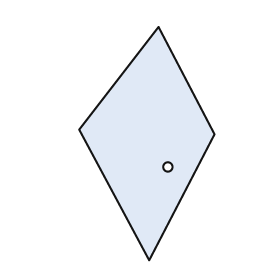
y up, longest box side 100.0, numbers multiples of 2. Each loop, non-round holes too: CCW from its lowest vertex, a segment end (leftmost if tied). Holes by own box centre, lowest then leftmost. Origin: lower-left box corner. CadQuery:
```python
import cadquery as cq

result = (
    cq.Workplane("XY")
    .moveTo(30.0, 0.0)
    .lineTo(58.0, 54.0)
    .lineTo(34.0, 100.0)
    .lineTo(0.0, 56.0)
    .close()
    .moveTo(38.0, 40.0)
    .circle(2.0)
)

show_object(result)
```